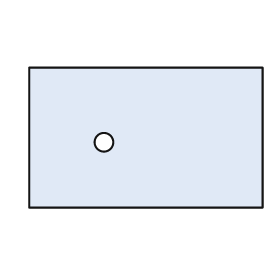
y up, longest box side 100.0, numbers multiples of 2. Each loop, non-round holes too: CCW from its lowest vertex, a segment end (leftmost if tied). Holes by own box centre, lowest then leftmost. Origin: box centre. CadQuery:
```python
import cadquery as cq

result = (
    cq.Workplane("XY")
    .moveTo(-50.0, -30.0)
    .lineTo(50.0, -30.0)
    .lineTo(50.0, 30.0)
    .lineTo(-50.0, 30.0)
    .close()
    .moveTo(-18.0, -2.0)
    .circle(4.0)
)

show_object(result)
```